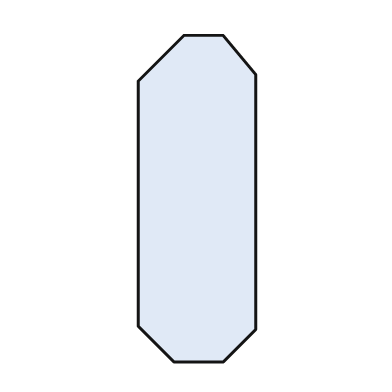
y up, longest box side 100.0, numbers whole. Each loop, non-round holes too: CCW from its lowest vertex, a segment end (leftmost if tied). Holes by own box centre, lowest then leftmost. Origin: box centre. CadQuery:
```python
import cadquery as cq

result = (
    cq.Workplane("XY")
    .moveTo(-7.0, -50.0)
    .lineTo(8.0, -50.0)
    .lineTo(18.0, -40.0)
    .lineTo(18.0, 38.0)
    .lineTo(8.0, 50.0)
    .lineTo(-4.0, 50.0)
    .lineTo(-18.0, 36.0)
    .lineTo(-18.0, -39.0)
    .close()
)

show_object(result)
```